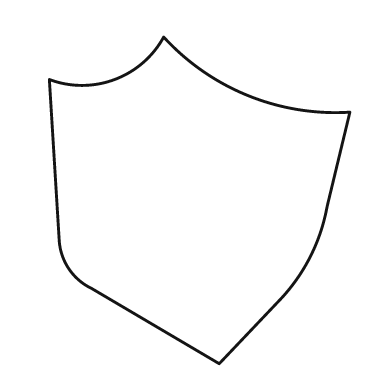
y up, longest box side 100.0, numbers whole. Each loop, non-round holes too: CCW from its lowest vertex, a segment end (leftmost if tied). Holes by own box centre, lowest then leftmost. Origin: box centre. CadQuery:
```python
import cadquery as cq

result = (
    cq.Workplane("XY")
    .moveTo(6.0, -50.0)
    .lineTo(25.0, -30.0)
    .threePointArc((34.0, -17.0), (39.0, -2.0))
    .lineTo(46.0, 27.0)
    .threePointArc((15.0, 32.0), (-11.0, 50.0))
    .threePointArc((-26.0, 37.0), (-46.0, 37.0))
    .lineTo(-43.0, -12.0)
    .threePointArc((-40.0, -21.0), (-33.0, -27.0))
    .close()
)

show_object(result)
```